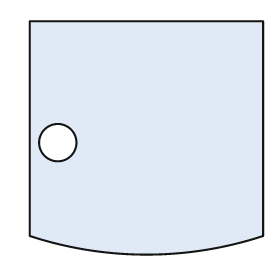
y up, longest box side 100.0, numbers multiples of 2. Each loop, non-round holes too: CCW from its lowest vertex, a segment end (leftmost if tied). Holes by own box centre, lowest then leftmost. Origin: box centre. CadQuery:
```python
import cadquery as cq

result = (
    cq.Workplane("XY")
    .moveTo(-50.0, -42.0)
    .threePointArc((0.0, -50.0), (50.0, -42.0))
    .lineTo(50.0, 50.0)
    .lineTo(-50.0, 50.0)
    .close()
    .moveTo(-38.0, -2.0)
    .circle(8.0)
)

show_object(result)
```